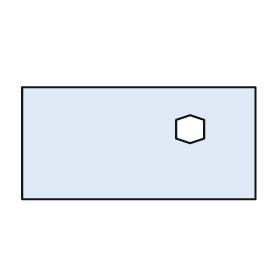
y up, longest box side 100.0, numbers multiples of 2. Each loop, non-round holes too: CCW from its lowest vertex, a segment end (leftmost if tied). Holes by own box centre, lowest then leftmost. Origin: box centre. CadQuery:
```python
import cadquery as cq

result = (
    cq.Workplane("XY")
    .moveTo(-50.0, -24.0)
    .lineTo(50.0, -24.0)
    .lineTo(50.0, 24.0)
    .lineTo(-50.0, 24.0)
    .close()
    .moveTo(22.0, 0.0)
    .lineTo(28.0, 2.0)
    .lineTo(28.0, 10.0)
    .lineTo(22.0, 12.0)
    .lineTo(16.0, 10.0)
    .lineTo(16.0, 2.0)
    .close()
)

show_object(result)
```